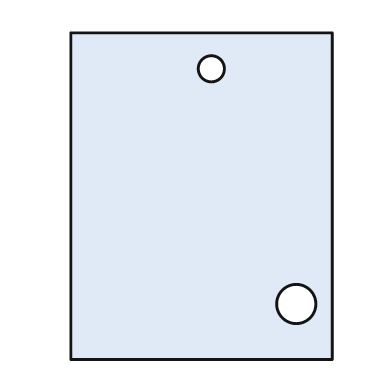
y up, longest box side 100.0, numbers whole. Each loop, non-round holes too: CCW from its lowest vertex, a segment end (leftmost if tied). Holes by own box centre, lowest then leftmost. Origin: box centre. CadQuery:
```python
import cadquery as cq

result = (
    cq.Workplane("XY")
    .moveTo(-40.0, -50.0)
    .lineTo(40.0, -50.0)
    .lineTo(40.0, 50.0)
    .lineTo(-40.0, 50.0)
    .close()
    .moveTo(29.0, -33.0)
    .circle(6.0)
    .moveTo(3.0, 39.0)
    .circle(4.0)
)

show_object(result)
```